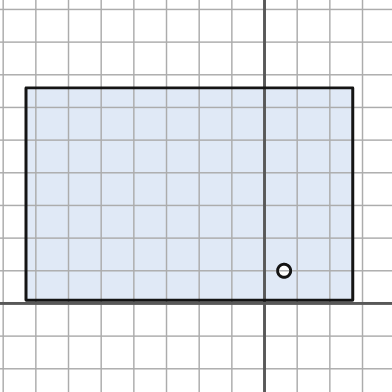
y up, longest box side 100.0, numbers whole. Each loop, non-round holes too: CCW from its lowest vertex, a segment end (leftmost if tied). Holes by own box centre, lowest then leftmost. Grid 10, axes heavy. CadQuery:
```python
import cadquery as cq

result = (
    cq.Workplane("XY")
    .moveTo(-73.0, 1.0)
    .lineTo(27.0, 1.0)
    .lineTo(27.0, 66.0)
    .lineTo(-73.0, 66.0)
    .close()
    .moveTo(6.0, 10.0)
    .circle(2.0)
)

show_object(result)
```